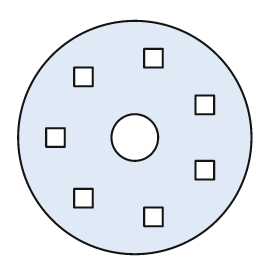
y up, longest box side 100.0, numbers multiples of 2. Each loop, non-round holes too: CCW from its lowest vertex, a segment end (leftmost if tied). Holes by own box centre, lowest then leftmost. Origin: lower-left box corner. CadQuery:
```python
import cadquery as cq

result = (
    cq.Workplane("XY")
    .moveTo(50.0, 50.0)
    .circle(50.0)
    .moveTo(54.0, 12.0)
    .lineTo(62.0, 12.0)
    .lineTo(62.0, 20.0)
    .lineTo(54.0, 20.0)
    .close()
    .moveTo(24.0, 20.0)
    .lineTo(32.0, 20.0)
    .lineTo(32.0, 28.0)
    .lineTo(24.0, 28.0)
    .close()
    .moveTo(76.0, 32.0)
    .lineTo(84.0, 32.0)
    .lineTo(84.0, 40.0)
    .lineTo(76.0, 40.0)
    .close()
    .moveTo(12.0, 46.0)
    .lineTo(20.0, 46.0)
    .lineTo(20.0, 54.0)
    .lineTo(12.0, 54.0)
    .close()
    .moveTo(50.0, 50.0)
    .circle(10.0)
    .moveTo(76.0, 60.0)
    .lineTo(84.0, 60.0)
    .lineTo(84.0, 68.0)
    .lineTo(76.0, 68.0)
    .close()
    .moveTo(24.0, 72.0)
    .lineTo(32.0, 72.0)
    .lineTo(32.0, 80.0)
    .lineTo(24.0, 80.0)
    .close()
    .moveTo(54.0, 80.0)
    .lineTo(62.0, 80.0)
    .lineTo(62.0, 88.0)
    .lineTo(54.0, 88.0)
    .close()
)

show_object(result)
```